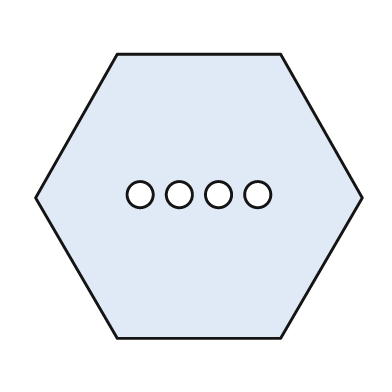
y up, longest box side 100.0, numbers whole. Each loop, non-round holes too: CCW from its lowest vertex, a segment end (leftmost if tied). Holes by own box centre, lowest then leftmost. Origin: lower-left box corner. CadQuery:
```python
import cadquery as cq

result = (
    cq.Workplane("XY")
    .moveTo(25.0, 0.0)
    .lineTo(75.0, 0.0)
    .lineTo(100.0, 43.0)
    .lineTo(75.0, 87.0)
    .lineTo(25.0, 87.0)
    .lineTo(0.0, 43.0)
    .close()
    .moveTo(32.0, 44.0)
    .circle(4.0)
    .moveTo(44.0, 44.0)
    .circle(4.0)
    .moveTo(56.0, 44.0)
    .circle(4.0)
    .moveTo(68.0, 44.0)
    .circle(4.0)
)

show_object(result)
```